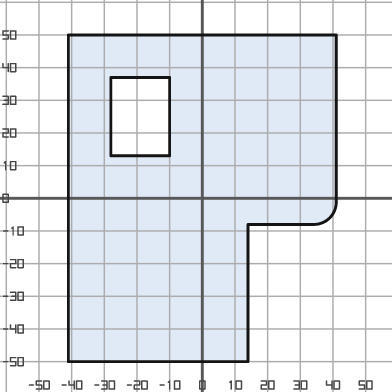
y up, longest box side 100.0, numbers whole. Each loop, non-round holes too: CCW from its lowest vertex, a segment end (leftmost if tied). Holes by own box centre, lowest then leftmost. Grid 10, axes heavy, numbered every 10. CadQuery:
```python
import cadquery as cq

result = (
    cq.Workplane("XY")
    .moveTo(-41.0, -50.0)
    .lineTo(14.0, -50.0)
    .lineTo(14.0, -8.0)
    .lineTo(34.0, -8.0)
    .threePointArc((39.0, -6.0), (41.0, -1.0))
    .lineTo(41.0, 50.0)
    .lineTo(-41.0, 50.0)
    .close()
    .moveTo(-28.0, 13.0)
    .lineTo(-10.0, 13.0)
    .lineTo(-10.0, 37.0)
    .lineTo(-28.0, 37.0)
    .close()
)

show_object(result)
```